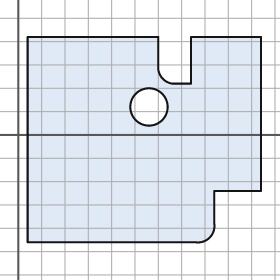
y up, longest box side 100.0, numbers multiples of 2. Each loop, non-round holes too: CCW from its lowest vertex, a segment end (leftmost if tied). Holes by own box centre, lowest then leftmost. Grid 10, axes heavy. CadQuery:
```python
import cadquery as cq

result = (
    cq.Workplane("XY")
    .moveTo(4.0, -46.0)
    .lineTo(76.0, -46.0)
    .threePointArc((82.0, -44.0), (84.0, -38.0))
    .lineTo(84.0, -24.0)
    .lineTo(104.0, -24.0)
    .lineTo(104.0, 42.0)
    .lineTo(74.0, 42.0)
    .lineTo(74.0, 22.0)
    .lineTo(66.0, 22.0)
    .threePointArc((62.0, 24.0), (60.0, 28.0))
    .lineTo(60.0, 42.0)
    .lineTo(4.0, 42.0)
    .close()
    .moveTo(56.0, 12.0)
    .circle(8.0)
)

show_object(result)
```